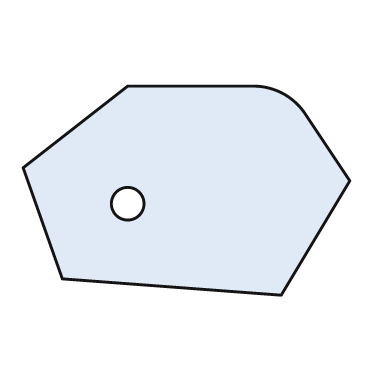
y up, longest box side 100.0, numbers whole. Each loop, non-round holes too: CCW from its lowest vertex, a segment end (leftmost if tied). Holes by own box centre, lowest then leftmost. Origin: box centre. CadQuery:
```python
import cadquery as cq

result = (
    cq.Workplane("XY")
    .moveTo(29.0, -32.0)
    .lineTo(50.0, 3.0)
    .lineTo(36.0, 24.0)
    .threePointArc((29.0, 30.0), (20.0, 32.0))
    .lineTo(-18.0, 32.0)
    .lineTo(-50.0, 7.0)
    .lineTo(-38.0, -27.0)
    .close()
    .moveTo(-18.0, -4.0)
    .circle(5.0)
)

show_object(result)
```